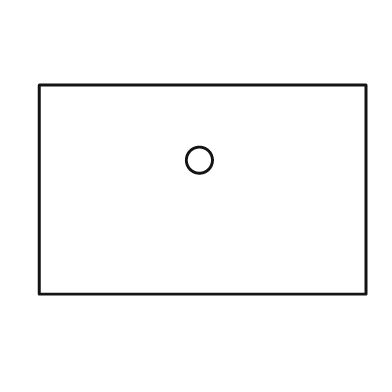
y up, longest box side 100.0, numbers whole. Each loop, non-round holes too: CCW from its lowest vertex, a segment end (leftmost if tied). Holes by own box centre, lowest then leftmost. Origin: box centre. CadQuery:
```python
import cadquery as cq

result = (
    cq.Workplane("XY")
    .moveTo(-50.0, -32.0)
    .lineTo(50.0, -32.0)
    .lineTo(50.0, 32.0)
    .lineTo(-50.0, 32.0)
    .close()
    .moveTo(-1.0, 9.0)
    .circle(4.0)
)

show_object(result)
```